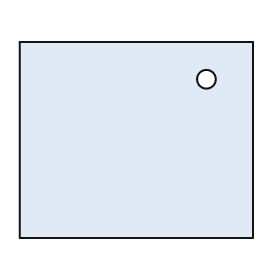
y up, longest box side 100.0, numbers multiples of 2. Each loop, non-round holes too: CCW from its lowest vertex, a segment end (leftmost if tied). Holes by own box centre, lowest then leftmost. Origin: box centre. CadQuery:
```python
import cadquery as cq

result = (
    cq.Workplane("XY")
    .moveTo(-50.0, -42.0)
    .lineTo(50.0, -42.0)
    .lineTo(50.0, 42.0)
    .lineTo(-50.0, 42.0)
    .close()
    .moveTo(30.0, 26.0)
    .circle(4.0)
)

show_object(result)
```